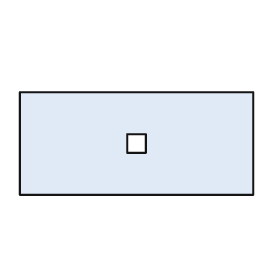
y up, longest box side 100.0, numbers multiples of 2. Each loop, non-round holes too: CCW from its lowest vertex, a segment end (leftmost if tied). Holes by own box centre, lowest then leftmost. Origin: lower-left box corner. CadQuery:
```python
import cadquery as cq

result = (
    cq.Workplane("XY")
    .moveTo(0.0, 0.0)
    .lineTo(100.0, 0.0)
    .lineTo(100.0, 44.0)
    .lineTo(0.0, 44.0)
    .close()
    .moveTo(46.0, 18.0)
    .lineTo(54.0, 18.0)
    .lineTo(54.0, 26.0)
    .lineTo(46.0, 26.0)
    .close()
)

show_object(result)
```